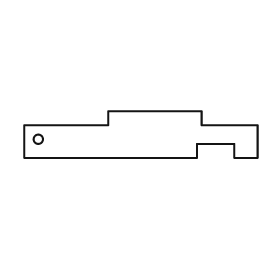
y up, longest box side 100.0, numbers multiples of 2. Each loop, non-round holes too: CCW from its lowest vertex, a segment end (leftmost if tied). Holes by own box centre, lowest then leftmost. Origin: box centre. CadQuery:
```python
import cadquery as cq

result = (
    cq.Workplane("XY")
    .moveTo(-50.0, -10.0)
    .lineTo(24.0, -10.0)
    .lineTo(24.0, -4.0)
    .lineTo(40.0, -4.0)
    .lineTo(40.0, -10.0)
    .lineTo(50.0, -10.0)
    .lineTo(50.0, 4.0)
    .lineTo(26.0, 4.0)
    .lineTo(26.0, 10.0)
    .lineTo(-14.0, 10.0)
    .lineTo(-14.0, 4.0)
    .lineTo(-50.0, 4.0)
    .close()
    .moveTo(-44.0, -2.0)
    .circle(2.0)
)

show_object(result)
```